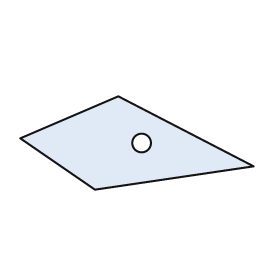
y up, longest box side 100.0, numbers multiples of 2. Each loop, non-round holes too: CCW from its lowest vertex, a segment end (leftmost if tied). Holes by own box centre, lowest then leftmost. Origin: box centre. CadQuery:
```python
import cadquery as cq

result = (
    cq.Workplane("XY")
    .moveTo(-18.0, -20.0)
    .lineTo(50.0, -10.0)
    .lineTo(-8.0, 20.0)
    .lineTo(-50.0, 2.0)
    .close()
    .moveTo(2.0, 0.0)
    .circle(4.0)
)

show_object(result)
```